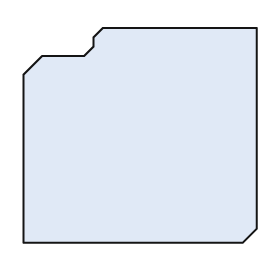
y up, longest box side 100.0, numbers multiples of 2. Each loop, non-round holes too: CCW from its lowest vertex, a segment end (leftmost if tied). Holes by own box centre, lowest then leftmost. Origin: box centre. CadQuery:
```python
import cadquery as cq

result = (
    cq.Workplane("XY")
    .moveTo(-50.0, -46.0)
    .lineTo(44.0, -46.0)
    .lineTo(50.0, -40.0)
    .lineTo(50.0, 46.0)
    .lineTo(-16.0, 46.0)
    .lineTo(-20.0, 42.0)
    .lineTo(-20.0, 38.0)
    .lineTo(-24.0, 34.0)
    .lineTo(-42.0, 34.0)
    .lineTo(-50.0, 26.0)
    .close()
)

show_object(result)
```